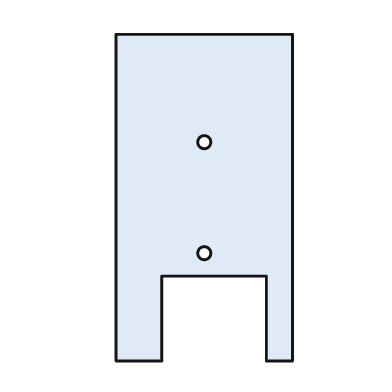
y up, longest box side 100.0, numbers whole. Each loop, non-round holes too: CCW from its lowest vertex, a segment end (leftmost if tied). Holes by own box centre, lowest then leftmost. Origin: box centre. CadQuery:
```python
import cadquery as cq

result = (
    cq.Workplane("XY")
    .moveTo(-27.0, -50.0)
    .lineTo(-13.0, -50.0)
    .lineTo(-13.0, -24.0)
    .lineTo(19.0, -24.0)
    .lineTo(19.0, -50.0)
    .lineTo(27.0, -50.0)
    .lineTo(27.0, 50.0)
    .lineTo(-27.0, 50.0)
    .close()
    .moveTo(0.0, -17.0)
    .circle(2.0)
    .moveTo(0.0, 17.0)
    .circle(2.0)
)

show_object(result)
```